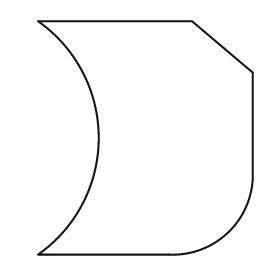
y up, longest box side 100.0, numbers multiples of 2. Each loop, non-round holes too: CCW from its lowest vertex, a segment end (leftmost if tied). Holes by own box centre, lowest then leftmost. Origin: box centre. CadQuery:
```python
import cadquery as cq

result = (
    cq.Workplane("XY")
    .moveTo(-46.0, -50.0)
    .lineTo(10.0, -50.0)
    .threePointArc((36.0, -40.0), (46.0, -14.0))
    .lineTo(46.0, 28.0)
    .lineTo(20.0, 50.0)
    .lineTo(-46.0, 50.0)
    .threePointArc((-20.0, 0.0), (-46.0, -50.0))
    .close()
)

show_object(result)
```